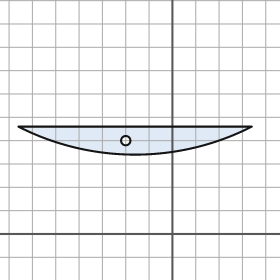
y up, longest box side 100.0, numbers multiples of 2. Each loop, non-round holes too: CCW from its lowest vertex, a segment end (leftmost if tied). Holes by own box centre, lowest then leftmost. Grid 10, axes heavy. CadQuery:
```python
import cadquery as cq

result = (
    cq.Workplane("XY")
    .moveTo(-66.0, 46.0)
    .threePointArc((-16.0, 34.0), (34.0, 46.0))
    .close()
    .moveTo(-20.0, 40.0)
    .circle(2.0)
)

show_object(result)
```